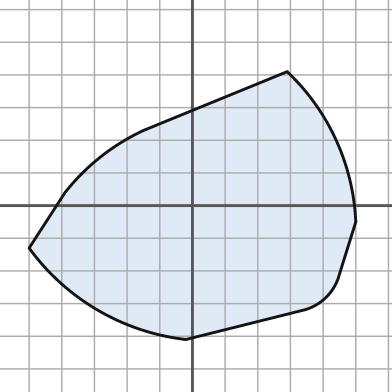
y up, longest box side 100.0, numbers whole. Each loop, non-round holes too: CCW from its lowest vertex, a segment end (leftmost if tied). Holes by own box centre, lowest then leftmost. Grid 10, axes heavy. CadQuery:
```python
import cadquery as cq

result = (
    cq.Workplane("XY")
    .moveTo(-2.0, -41.0)
    .lineTo(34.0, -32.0)
    .threePointArc((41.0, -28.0), (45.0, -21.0))
    .lineTo(50.0, -5.0)
    .threePointArc((44.0, 20.0), (29.0, 41.0))
    .lineTo(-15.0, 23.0)
    .threePointArc((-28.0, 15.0), (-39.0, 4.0))
    .lineTo(-50.0, -13.0)
    .threePointArc((-29.0, -32.0), (-2.0, -41.0))
    .close()
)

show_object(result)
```